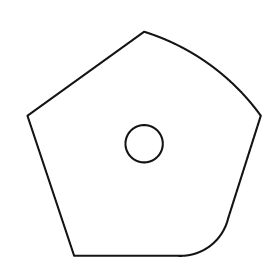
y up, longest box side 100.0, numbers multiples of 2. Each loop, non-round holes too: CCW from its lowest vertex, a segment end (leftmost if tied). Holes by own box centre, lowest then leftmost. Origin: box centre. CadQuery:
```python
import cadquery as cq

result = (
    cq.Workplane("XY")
    .moveTo(-30.0, -48.0)
    .lineTo(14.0, -48.0)
    .threePointArc((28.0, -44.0), (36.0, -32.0))
    .lineTo(50.0, 12.0)
    .threePointArc((28.0, 34.0), (0.0, 48.0))
    .lineTo(-50.0, 12.0)
    .close()
    .moveTo(0.0, 0.0)
    .circle(8.0)
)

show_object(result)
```